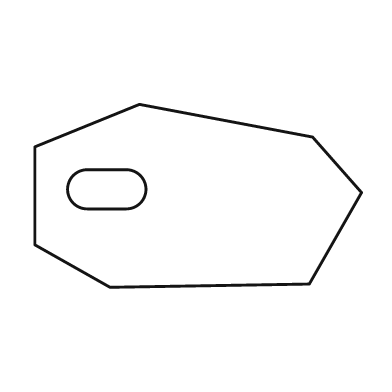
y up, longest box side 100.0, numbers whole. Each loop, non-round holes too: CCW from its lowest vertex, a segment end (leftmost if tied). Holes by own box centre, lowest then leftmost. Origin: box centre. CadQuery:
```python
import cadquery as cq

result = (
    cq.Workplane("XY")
    .moveTo(-27.0, -28.0)
    .lineTo(34.0, -27.0)
    .lineTo(50.0, 1.0)
    .lineTo(35.0, 18.0)
    .lineTo(-18.0, 28.0)
    .lineTo(-50.0, 15.0)
    .lineTo(-50.0, -15.0)
    .close()
    .moveTo(-34.0, -4.0)
    .lineTo(-22.0, -4.0)
    .threePointArc((-16.0, 2.0), (-22.0, 8.0))
    .lineTo(-34.0, 8.0)
    .threePointArc((-40.0, 2.0), (-34.0, -4.0))
    .close()
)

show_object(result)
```